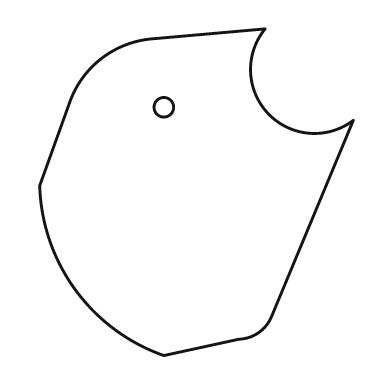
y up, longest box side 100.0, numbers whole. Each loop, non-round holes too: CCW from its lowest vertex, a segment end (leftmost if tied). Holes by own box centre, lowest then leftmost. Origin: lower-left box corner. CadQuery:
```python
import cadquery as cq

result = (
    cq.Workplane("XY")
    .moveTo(38.0, 0.0)
    .lineTo(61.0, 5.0)
    .threePointArc((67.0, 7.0), (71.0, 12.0))
    .lineTo(96.0, 72.0)
    .threePointArc((70.0, 74.0), (69.0, 100.0))
    .lineTo(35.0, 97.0)
    .threePointArc((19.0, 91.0), (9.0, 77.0))
    .lineTo(0.0, 52.0)
    .threePointArc((11.0, 20.0), (38.0, 0.0))
    .close()
    .moveTo(38.0, 76.0)
    .circle(3.0)
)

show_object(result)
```